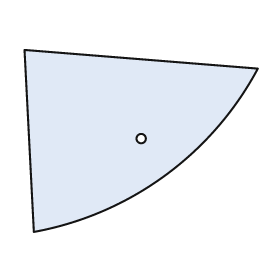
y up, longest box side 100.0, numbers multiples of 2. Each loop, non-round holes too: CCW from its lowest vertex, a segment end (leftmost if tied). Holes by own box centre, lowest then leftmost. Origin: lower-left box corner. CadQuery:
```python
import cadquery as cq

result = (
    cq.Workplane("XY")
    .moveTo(4.0, 0.0)
    .threePointArc((60.0, 24.0), (100.0, 70.0))
    .lineTo(0.0, 78.0)
    .close()
    .moveTo(50.0, 40.0)
    .circle(2.0)
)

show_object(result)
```